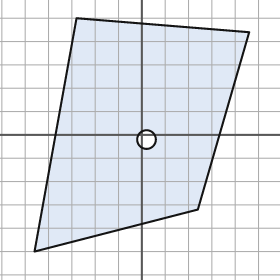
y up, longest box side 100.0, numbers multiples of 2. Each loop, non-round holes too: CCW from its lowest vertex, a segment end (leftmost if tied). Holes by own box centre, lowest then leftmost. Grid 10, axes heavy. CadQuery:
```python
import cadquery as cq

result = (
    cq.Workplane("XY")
    .moveTo(-46.0, -50.0)
    .lineTo(24.0, -32.0)
    .lineTo(46.0, 44.0)
    .lineTo(-28.0, 50.0)
    .close()
    .moveTo(2.0, -2.0)
    .circle(4.0)
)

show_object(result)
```